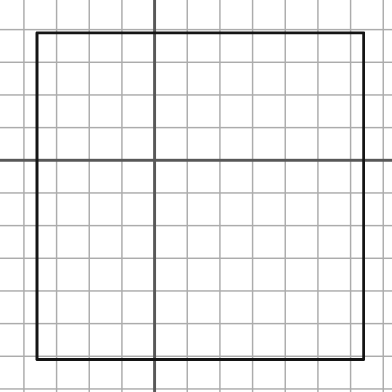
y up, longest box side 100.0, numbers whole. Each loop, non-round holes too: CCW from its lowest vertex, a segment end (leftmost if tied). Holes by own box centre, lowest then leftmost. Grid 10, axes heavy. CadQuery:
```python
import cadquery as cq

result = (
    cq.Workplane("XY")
    .moveTo(-36.0, -61.0)
    .lineTo(64.0, -61.0)
    .lineTo(64.0, 39.0)
    .lineTo(-36.0, 39.0)
    .close()
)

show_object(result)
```